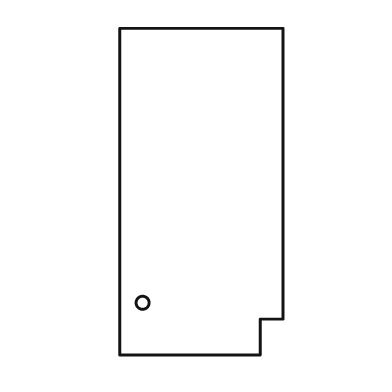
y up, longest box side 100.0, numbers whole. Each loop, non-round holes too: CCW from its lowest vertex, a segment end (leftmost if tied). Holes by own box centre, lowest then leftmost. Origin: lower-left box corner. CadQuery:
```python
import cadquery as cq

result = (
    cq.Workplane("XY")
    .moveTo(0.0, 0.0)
    .lineTo(43.0, 0.0)
    .lineTo(43.0, 11.0)
    .lineTo(50.0, 11.0)
    .lineTo(50.0, 100.0)
    .lineTo(0.0, 100.0)
    .close()
    .moveTo(7.0, 16.0)
    .circle(2.0)
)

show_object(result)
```